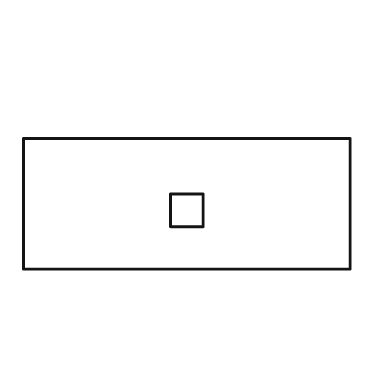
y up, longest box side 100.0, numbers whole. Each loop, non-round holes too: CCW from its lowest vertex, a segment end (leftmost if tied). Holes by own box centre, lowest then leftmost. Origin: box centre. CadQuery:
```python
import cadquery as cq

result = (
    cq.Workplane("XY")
    .moveTo(-50.0, -20.0)
    .lineTo(50.0, -20.0)
    .lineTo(50.0, 20.0)
    .lineTo(-50.0, 20.0)
    .close()
    .moveTo(-5.0, -7.0)
    .lineTo(5.0, -7.0)
    .lineTo(5.0, 3.0)
    .lineTo(-5.0, 3.0)
    .close()
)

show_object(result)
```